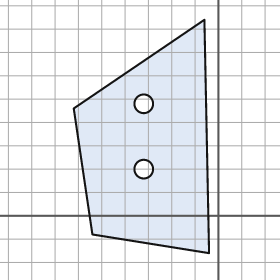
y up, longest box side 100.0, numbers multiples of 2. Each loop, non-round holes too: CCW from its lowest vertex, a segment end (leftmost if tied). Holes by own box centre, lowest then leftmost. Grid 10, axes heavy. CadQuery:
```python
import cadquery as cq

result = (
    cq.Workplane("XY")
    .moveTo(-4.0, -16.0)
    .lineTo(-6.0, 84.0)
    .lineTo(-62.0, 46.0)
    .lineTo(-54.0, -8.0)
    .close()
    .moveTo(-32.0, 20.0)
    .circle(4.0)
    .moveTo(-32.0, 48.0)
    .circle(4.0)
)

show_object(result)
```